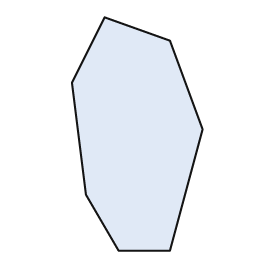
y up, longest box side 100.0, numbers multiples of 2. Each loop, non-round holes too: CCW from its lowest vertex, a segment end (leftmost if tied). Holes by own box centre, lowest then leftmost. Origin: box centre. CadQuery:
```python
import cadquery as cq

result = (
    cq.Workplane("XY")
    .moveTo(-8.0, -50.0)
    .lineTo(14.0, -50.0)
    .lineTo(28.0, 2.0)
    .lineTo(14.0, 40.0)
    .lineTo(-14.0, 50.0)
    .lineTo(-28.0, 22.0)
    .lineTo(-22.0, -26.0)
    .close()
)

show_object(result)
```